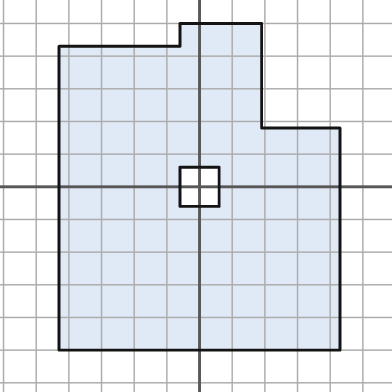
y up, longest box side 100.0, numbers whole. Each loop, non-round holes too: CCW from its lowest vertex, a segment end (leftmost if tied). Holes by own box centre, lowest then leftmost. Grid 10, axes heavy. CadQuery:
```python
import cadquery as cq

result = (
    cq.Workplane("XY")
    .moveTo(-43.0, -50.0)
    .lineTo(43.0, -50.0)
    .lineTo(43.0, 18.0)
    .lineTo(19.0, 18.0)
    .lineTo(19.0, 50.0)
    .lineTo(-6.0, 50.0)
    .lineTo(-6.0, 43.0)
    .lineTo(-43.0, 43.0)
    .close()
    .moveTo(-6.0, -6.0)
    .lineTo(6.0, -6.0)
    .lineTo(6.0, 6.0)
    .lineTo(-6.0, 6.0)
    .close()
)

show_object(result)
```